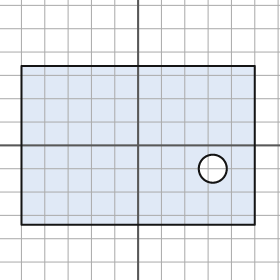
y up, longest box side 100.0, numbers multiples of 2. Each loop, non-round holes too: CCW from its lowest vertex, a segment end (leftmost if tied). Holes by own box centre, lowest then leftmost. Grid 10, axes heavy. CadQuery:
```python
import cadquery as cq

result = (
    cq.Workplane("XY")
    .moveTo(-50.0, -34.0)
    .lineTo(50.0, -34.0)
    .lineTo(50.0, 34.0)
    .lineTo(-50.0, 34.0)
    .close()
    .moveTo(32.0, -10.0)
    .circle(6.0)
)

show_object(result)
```